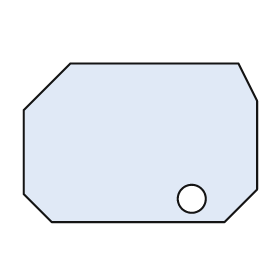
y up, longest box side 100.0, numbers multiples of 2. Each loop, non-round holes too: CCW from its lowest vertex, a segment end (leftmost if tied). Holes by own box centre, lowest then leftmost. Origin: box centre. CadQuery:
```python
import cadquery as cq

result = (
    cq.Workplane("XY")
    .moveTo(-38.0, -34.0)
    .lineTo(36.0, -34.0)
    .lineTo(50.0, -20.0)
    .lineTo(50.0, 18.0)
    .lineTo(42.0, 34.0)
    .lineTo(-30.0, 34.0)
    .lineTo(-50.0, 14.0)
    .lineTo(-50.0, -22.0)
    .close()
    .moveTo(22.0, -24.0)
    .circle(6.0)
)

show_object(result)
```